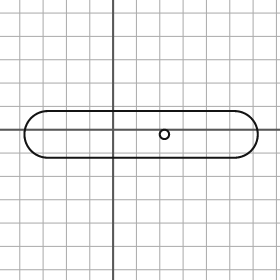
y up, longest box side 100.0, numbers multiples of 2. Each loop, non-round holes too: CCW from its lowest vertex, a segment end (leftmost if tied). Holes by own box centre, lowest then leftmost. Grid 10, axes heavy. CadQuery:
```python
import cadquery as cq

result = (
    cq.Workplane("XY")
    .moveTo(-28.0, -12.0)
    .lineTo(52.0, -12.0)
    .threePointArc((62.0, -2.0), (52.0, 8.0))
    .lineTo(-28.0, 8.0)
    .threePointArc((-38.0, -2.0), (-28.0, -12.0))
    .close()
    .moveTo(22.0, -2.0)
    .circle(2.0)
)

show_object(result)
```